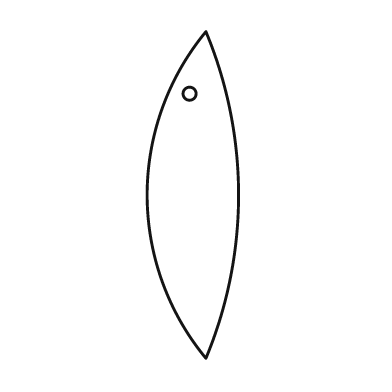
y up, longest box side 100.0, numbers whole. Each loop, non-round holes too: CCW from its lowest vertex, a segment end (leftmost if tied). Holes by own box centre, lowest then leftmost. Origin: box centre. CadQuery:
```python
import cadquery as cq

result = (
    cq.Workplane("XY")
    .moveTo(4.0, -50.0)
    .threePointArc((14.0, 0.0), (4.0, 50.0))
    .threePointArc((-14.0, 0.0), (4.0, -50.0))
    .close()
    .moveTo(-1.0, 31.0)
    .circle(2.0)
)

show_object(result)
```